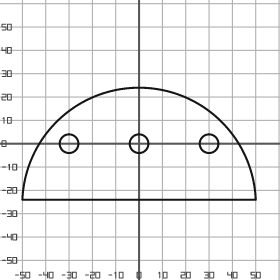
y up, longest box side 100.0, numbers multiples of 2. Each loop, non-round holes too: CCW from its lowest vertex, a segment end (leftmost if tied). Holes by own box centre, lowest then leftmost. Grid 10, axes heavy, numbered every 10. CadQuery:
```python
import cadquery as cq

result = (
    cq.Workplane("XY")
    .moveTo(-50.0, -24.0)
    .lineTo(50.0, -24.0)
    .threePointArc((0.0, 24.0), (-50.0, -24.0))
    .close()
    .moveTo(-30.0, 0.0)
    .circle(4.0)
    .moveTo(0.0, 0.0)
    .circle(4.0)
    .moveTo(30.0, 0.0)
    .circle(4.0)
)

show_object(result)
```